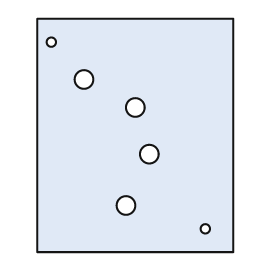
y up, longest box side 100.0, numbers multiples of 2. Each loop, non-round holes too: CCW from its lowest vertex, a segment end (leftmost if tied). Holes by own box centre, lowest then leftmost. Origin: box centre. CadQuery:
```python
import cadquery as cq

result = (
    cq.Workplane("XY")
    .moveTo(-42.0, -50.0)
    .lineTo(42.0, -50.0)
    .lineTo(42.0, 50.0)
    .lineTo(-42.0, 50.0)
    .close()
    .moveTo(30.0, -40.0)
    .circle(2.0)
    .moveTo(-4.0, -30.0)
    .circle(4.0)
    .moveTo(6.0, -8.0)
    .circle(4.0)
    .moveTo(0.0, 12.0)
    .circle(4.0)
    .moveTo(-22.0, 24.0)
    .circle(4.0)
    .moveTo(-36.0, 40.0)
    .circle(2.0)
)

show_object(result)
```